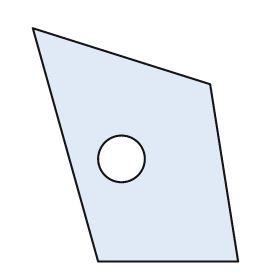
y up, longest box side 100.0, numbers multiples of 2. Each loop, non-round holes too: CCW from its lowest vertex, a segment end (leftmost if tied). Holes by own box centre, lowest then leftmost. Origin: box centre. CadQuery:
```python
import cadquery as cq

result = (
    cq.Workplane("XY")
    .moveTo(-16.0, -50.0)
    .lineTo(44.0, -50.0)
    .lineTo(32.0, 26.0)
    .lineTo(-44.0, 50.0)
    .close()
    .moveTo(-6.0, -6.0)
    .circle(10.0)
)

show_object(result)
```